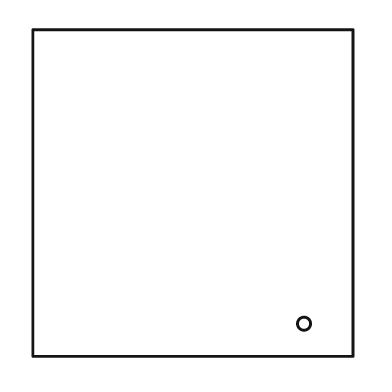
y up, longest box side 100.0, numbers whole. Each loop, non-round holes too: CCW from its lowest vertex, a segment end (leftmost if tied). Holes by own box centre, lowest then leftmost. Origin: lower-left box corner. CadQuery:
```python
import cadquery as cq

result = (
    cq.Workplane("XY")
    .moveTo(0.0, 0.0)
    .lineTo(98.0, 0.0)
    .lineTo(98.0, 100.0)
    .lineTo(0.0, 100.0)
    .close()
    .moveTo(83.0, 10.0)
    .circle(2.0)
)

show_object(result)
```